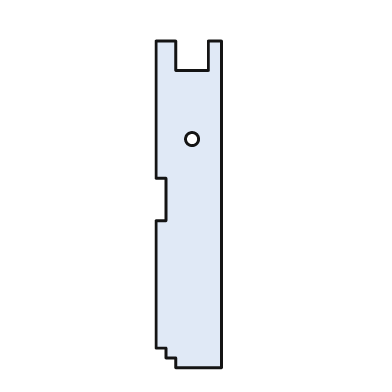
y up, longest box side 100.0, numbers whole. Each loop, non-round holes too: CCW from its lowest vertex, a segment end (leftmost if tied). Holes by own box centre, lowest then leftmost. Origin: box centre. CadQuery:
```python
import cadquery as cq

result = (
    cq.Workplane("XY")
    .moveTo(-4.0, -50.0)
    .lineTo(10.0, -50.0)
    .lineTo(10.0, 50.0)
    .lineTo(6.0, 50.0)
    .lineTo(6.0, 41.0)
    .lineTo(-4.0, 41.0)
    .lineTo(-4.0, 50.0)
    .lineTo(-10.0, 50.0)
    .lineTo(-10.0, 8.0)
    .lineTo(-7.0, 8.0)
    .lineTo(-7.0, -5.0)
    .lineTo(-10.0, -5.0)
    .lineTo(-10.0, -44.0)
    .lineTo(-7.0, -44.0)
    .lineTo(-7.0, -47.0)
    .lineTo(-4.0, -47.0)
    .close()
    .moveTo(1.0, 20.0)
    .circle(2.0)
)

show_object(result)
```